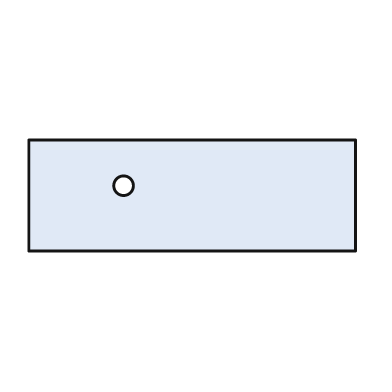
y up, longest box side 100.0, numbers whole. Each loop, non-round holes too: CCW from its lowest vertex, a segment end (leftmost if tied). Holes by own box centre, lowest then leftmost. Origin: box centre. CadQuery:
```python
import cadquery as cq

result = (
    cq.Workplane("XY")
    .moveTo(-50.0, -17.0)
    .lineTo(50.0, -17.0)
    .lineTo(50.0, 17.0)
    .lineTo(-50.0, 17.0)
    .close()
    .moveTo(-21.0, 3.0)
    .circle(3.0)
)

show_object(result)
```